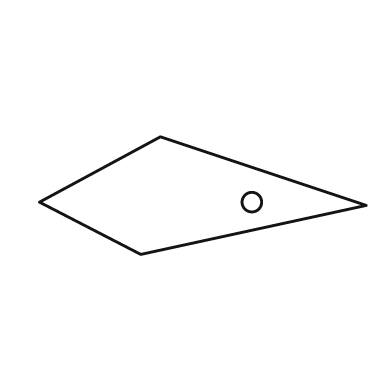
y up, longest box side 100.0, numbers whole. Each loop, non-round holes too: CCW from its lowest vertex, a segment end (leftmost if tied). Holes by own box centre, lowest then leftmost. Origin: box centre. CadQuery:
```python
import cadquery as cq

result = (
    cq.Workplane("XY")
    .moveTo(-19.0, -18.0)
    .lineTo(50.0, -3.0)
    .lineTo(-13.0, 18.0)
    .lineTo(-50.0, -2.0)
    .close()
    .moveTo(15.0, -2.0)
    .circle(3.0)
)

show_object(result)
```